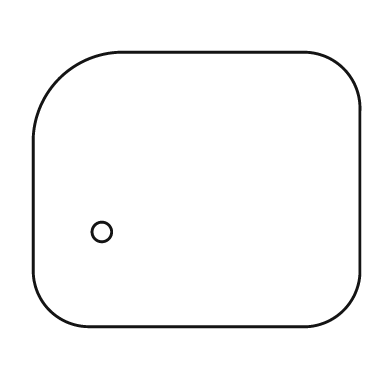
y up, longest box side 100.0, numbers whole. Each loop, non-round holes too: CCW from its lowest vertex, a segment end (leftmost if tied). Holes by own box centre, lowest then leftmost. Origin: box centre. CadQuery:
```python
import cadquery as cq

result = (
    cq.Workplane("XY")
    .moveTo(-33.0, -42.0)
    .lineTo(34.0, -42.0)
    .threePointArc((45.0, -37.0), (50.0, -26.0))
    .lineTo(50.0, 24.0)
    .threePointArc((45.0, 37.0), (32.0, 42.0))
    .lineTo(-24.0, 42.0)
    .threePointArc((-42.0, 34.0), (-50.0, 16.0))
    .lineTo(-50.0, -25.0)
    .threePointArc((-45.0, -37.0), (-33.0, -42.0))
    .close()
    .moveTo(-29.0, -13.0)
    .circle(3.0)
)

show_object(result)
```